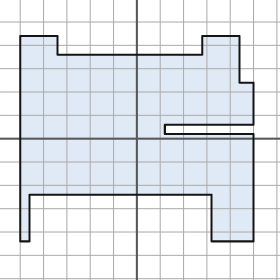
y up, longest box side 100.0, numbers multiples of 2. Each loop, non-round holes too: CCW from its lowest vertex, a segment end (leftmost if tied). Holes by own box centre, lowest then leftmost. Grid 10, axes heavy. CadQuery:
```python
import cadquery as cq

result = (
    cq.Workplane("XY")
    .moveTo(-50.0, -44.0)
    .lineTo(-46.0, -44.0)
    .lineTo(-46.0, -24.0)
    .lineTo(32.0, -24.0)
    .lineTo(32.0, -44.0)
    .lineTo(50.0, -44.0)
    .lineTo(50.0, 2.0)
    .lineTo(12.0, 2.0)
    .lineTo(12.0, 6.0)
    .lineTo(50.0, 6.0)
    .lineTo(50.0, 24.0)
    .lineTo(44.0, 24.0)
    .lineTo(44.0, 44.0)
    .lineTo(28.0, 44.0)
    .lineTo(28.0, 36.0)
    .lineTo(-34.0, 36.0)
    .lineTo(-34.0, 44.0)
    .lineTo(-50.0, 44.0)
    .close()
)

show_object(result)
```